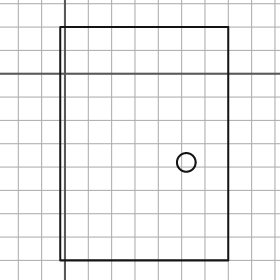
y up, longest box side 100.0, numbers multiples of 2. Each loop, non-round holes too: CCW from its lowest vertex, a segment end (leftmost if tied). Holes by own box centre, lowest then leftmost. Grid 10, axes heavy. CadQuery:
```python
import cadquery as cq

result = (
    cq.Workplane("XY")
    .moveTo(-2.0, -80.0)
    .lineTo(70.0, -80.0)
    .lineTo(70.0, 20.0)
    .lineTo(-2.0, 20.0)
    .close()
    .moveTo(52.0, -38.0)
    .circle(4.0)
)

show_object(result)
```